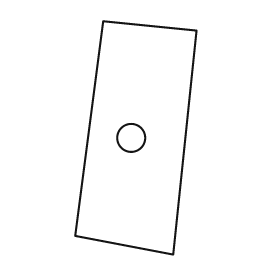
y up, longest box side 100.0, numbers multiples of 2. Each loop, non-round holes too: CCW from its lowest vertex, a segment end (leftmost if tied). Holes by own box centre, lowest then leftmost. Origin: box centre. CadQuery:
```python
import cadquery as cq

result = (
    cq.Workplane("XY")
    .moveTo(16.0, -50.0)
    .lineTo(26.0, 46.0)
    .lineTo(-14.0, 50.0)
    .lineTo(-26.0, -42.0)
    .close()
    .moveTo(-2.0, 0.0)
    .circle(6.0)
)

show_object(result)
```